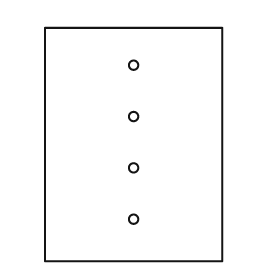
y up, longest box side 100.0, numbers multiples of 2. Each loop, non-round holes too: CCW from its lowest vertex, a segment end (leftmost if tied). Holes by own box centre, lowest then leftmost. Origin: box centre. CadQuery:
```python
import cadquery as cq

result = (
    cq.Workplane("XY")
    .moveTo(-38.0, -50.0)
    .lineTo(38.0, -50.0)
    .lineTo(38.0, 50.0)
    .lineTo(-38.0, 50.0)
    .close()
    .moveTo(0.0, -32.0)
    .circle(2.0)
    .moveTo(0.0, -10.0)
    .circle(2.0)
    .moveTo(0.0, 12.0)
    .circle(2.0)
    .moveTo(0.0, 34.0)
    .circle(2.0)
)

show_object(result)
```